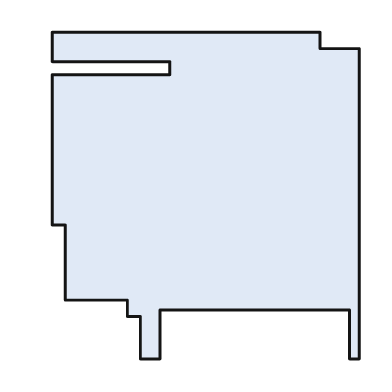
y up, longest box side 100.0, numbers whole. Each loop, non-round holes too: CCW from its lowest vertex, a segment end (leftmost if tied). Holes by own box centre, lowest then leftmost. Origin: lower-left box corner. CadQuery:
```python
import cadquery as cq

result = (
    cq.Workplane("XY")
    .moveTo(27.0, 0.0)
    .lineTo(33.0, 0.0)
    .lineTo(33.0, 15.0)
    .lineTo(91.0, 15.0)
    .lineTo(91.0, 0.0)
    .lineTo(94.0, 0.0)
    .lineTo(94.0, 95.0)
    .lineTo(82.0, 95.0)
    .lineTo(82.0, 100.0)
    .lineTo(0.0, 100.0)
    .lineTo(0.0, 91.0)
    .lineTo(36.0, 91.0)
    .lineTo(36.0, 87.0)
    .lineTo(0.0, 87.0)
    .lineTo(0.0, 41.0)
    .lineTo(4.0, 41.0)
    .lineTo(4.0, 18.0)
    .lineTo(23.0, 18.0)
    .lineTo(23.0, 13.0)
    .lineTo(27.0, 13.0)
    .close()
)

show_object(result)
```